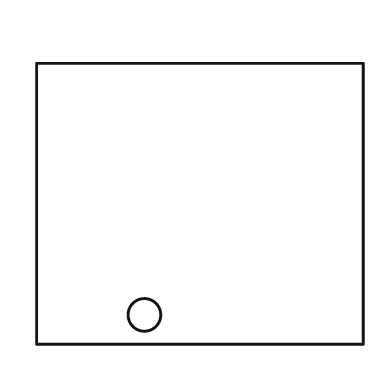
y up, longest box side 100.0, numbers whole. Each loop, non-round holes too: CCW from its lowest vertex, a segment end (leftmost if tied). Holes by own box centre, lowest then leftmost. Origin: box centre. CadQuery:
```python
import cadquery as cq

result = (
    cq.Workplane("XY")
    .moveTo(-50.0, -43.0)
    .lineTo(50.0, -43.0)
    .lineTo(50.0, 43.0)
    .lineTo(-50.0, 43.0)
    .close()
    .moveTo(-17.0, -34.0)
    .circle(5.0)
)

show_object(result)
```